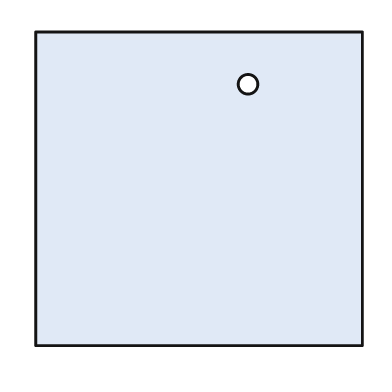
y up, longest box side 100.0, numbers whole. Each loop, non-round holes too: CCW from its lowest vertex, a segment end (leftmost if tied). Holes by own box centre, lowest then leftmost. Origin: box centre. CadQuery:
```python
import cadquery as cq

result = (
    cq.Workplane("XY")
    .moveTo(-50.0, -48.0)
    .lineTo(50.0, -48.0)
    .lineTo(50.0, 48.0)
    .lineTo(-50.0, 48.0)
    .close()
    .moveTo(15.0, 32.0)
    .circle(3.0)
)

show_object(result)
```